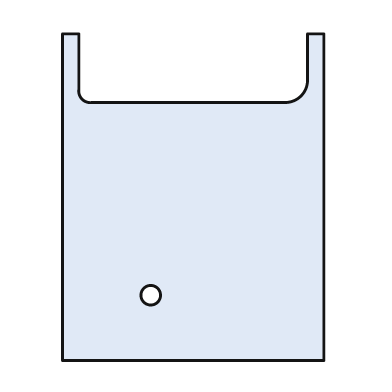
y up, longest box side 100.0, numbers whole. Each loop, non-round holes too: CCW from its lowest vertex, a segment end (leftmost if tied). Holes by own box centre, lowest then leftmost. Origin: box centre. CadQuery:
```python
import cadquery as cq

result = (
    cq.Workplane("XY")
    .moveTo(-40.0, -50.0)
    .lineTo(40.0, -50.0)
    .lineTo(40.0, 50.0)
    .lineTo(35.0, 50.0)
    .lineTo(35.0, 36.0)
    .threePointArc((33.0, 31.0), (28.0, 29.0))
    .lineTo(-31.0, 29.0)
    .threePointArc((-34.0, 30.0), (-35.0, 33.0))
    .lineTo(-35.0, 50.0)
    .lineTo(-40.0, 50.0)
    .close()
    .moveTo(-13.0, -30.0)
    .circle(3.0)
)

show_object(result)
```